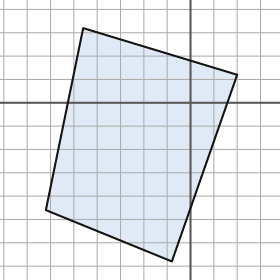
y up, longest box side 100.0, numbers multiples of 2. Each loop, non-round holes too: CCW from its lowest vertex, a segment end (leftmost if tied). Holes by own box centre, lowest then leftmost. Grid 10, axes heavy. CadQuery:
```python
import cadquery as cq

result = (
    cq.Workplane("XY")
    .moveTo(-8.0, -68.0)
    .lineTo(20.0, 12.0)
    .lineTo(-46.0, 32.0)
    .lineTo(-62.0, -46.0)
    .close()
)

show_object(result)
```